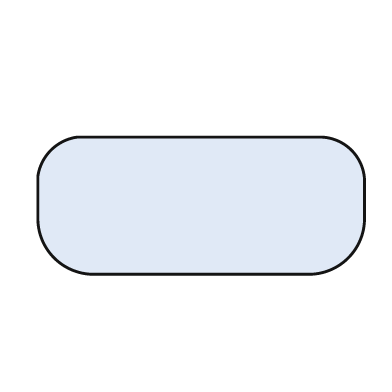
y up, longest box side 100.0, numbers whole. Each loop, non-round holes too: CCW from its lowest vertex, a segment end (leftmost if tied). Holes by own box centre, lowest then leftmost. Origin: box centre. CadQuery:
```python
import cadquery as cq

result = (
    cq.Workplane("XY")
    .moveTo(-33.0, -21.0)
    .lineTo(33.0, -21.0)
    .threePointArc((45.0, -16.0), (50.0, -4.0))
    .lineTo(50.0, 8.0)
    .threePointArc((46.0, 17.0), (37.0, 21.0))
    .lineTo(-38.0, 21.0)
    .threePointArc((-46.0, 17.0), (-50.0, 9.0))
    .lineTo(-50.0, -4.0)
    .threePointArc((-45.0, -16.0), (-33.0, -21.0))
    .close()
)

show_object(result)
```